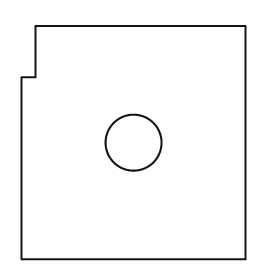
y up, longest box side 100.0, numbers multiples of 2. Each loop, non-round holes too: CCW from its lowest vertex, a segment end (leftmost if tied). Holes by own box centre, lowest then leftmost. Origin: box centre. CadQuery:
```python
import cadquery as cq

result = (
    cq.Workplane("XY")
    .moveTo(-48.0, -50.0)
    .lineTo(48.0, -50.0)
    .lineTo(48.0, 50.0)
    .lineTo(-42.0, 50.0)
    .lineTo(-42.0, 28.0)
    .lineTo(-48.0, 28.0)
    .close()
    .moveTo(0.0, 0.0)
    .circle(12.0)
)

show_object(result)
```